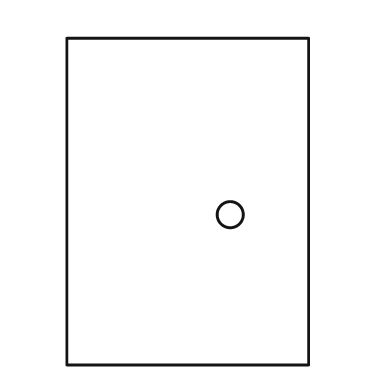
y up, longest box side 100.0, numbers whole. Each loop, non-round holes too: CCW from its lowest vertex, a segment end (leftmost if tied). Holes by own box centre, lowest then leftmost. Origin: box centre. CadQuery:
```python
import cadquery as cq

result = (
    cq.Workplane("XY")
    .moveTo(-37.0, -50.0)
    .lineTo(37.0, -50.0)
    .lineTo(37.0, 50.0)
    .lineTo(-37.0, 50.0)
    .close()
    .moveTo(13.0, -4.0)
    .circle(4.0)
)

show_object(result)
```